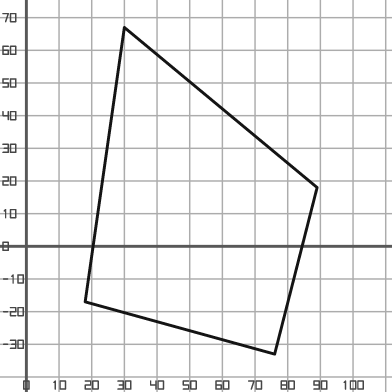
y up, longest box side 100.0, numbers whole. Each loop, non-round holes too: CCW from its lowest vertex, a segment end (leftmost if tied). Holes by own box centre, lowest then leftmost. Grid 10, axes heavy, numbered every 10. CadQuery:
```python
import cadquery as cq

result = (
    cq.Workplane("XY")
    .moveTo(76.0, -33.0)
    .lineTo(89.0, 18.0)
    .lineTo(30.0, 67.0)
    .lineTo(18.0, -17.0)
    .close()
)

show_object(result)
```